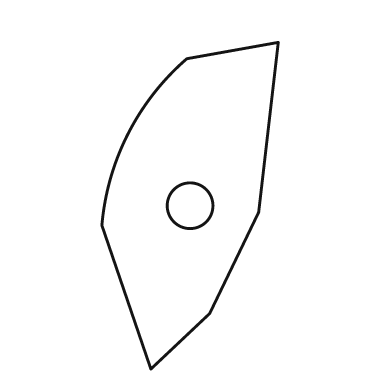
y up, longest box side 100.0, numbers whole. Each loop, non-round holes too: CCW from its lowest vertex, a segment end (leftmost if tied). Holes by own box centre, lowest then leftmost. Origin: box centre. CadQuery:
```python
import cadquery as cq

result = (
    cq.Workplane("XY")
    .moveTo(-12.0, -50.0)
    .lineTo(6.0, -33.0)
    .lineTo(21.0, -2.0)
    .lineTo(27.0, 50.0)
    .lineTo(-1.0, 45.0)
    .threePointArc((-19.0, 22.0), (-27.0, -6.0))
    .close()
    .moveTo(0.0, 0.0)
    .circle(7.0)
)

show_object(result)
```